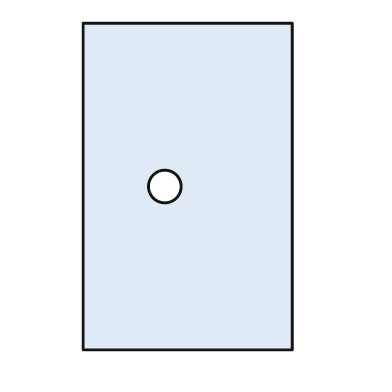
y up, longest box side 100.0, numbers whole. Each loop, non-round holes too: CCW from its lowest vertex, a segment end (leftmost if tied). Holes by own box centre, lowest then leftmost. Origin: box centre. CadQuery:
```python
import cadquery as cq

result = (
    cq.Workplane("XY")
    .moveTo(-32.0, -50.0)
    .lineTo(32.0, -50.0)
    .lineTo(32.0, 50.0)
    .lineTo(-32.0, 50.0)
    .close()
    .moveTo(-7.0, 0.0)
    .circle(5.0)
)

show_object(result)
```